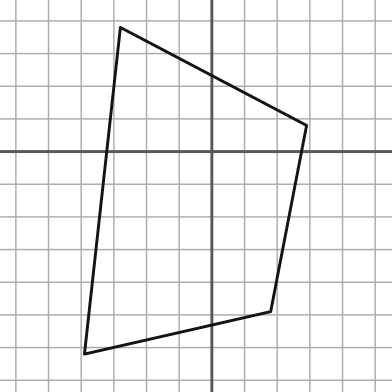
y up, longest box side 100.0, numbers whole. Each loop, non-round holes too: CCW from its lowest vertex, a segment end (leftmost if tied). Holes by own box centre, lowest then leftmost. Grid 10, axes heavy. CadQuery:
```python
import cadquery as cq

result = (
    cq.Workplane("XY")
    .moveTo(-39.0, -62.0)
    .lineTo(18.0, -49.0)
    .lineTo(29.0, 8.0)
    .lineTo(-28.0, 38.0)
    .close()
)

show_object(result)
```